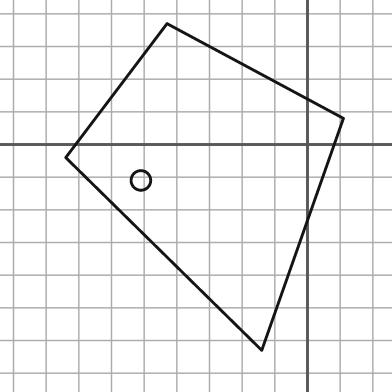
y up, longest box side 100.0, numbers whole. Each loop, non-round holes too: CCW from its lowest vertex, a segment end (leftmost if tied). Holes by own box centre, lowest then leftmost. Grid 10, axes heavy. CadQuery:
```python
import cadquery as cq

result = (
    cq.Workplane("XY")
    .moveTo(-14.0, -63.0)
    .lineTo(11.0, 8.0)
    .lineTo(-43.0, 37.0)
    .lineTo(-74.0, -4.0)
    .close()
    .moveTo(-51.0, -11.0)
    .circle(3.0)
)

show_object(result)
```